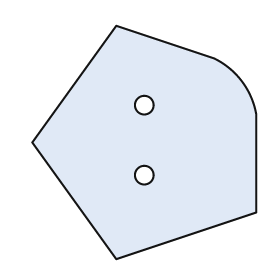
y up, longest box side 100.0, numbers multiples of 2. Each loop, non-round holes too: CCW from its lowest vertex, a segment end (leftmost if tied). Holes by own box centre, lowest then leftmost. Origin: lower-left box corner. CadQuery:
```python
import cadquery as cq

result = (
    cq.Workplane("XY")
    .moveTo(36.0, 0.0)
    .lineTo(96.0, 20.0)
    .lineTo(96.0, 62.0)
    .threePointArc((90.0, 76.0), (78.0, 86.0))
    .lineTo(36.0, 100.0)
    .lineTo(0.0, 50.0)
    .close()
    .moveTo(48.0, 36.0)
    .circle(4.0)
    .moveTo(48.0, 66.0)
    .circle(4.0)
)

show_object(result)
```